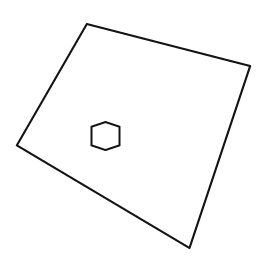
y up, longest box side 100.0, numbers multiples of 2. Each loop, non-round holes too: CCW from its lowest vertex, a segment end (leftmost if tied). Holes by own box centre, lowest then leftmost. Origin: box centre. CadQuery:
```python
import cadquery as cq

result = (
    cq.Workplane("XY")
    .moveTo(24.0, -48.0)
    .lineTo(50.0, 30.0)
    .lineTo(-20.0, 48.0)
    .lineTo(-50.0, -4.0)
    .close()
    .moveTo(-12.0, -6.0)
    .lineTo(-6.0, -4.0)
    .lineTo(-6.0, 4.0)
    .lineTo(-12.0, 6.0)
    .lineTo(-18.0, 4.0)
    .lineTo(-18.0, -4.0)
    .close()
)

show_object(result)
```